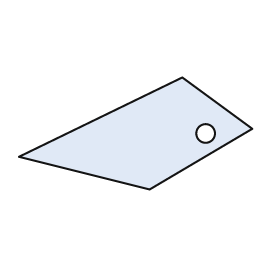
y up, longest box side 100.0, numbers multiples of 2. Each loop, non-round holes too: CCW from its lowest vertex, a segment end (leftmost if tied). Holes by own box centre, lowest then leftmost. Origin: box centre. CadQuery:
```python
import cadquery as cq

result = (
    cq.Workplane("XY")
    .moveTo(6.0, -24.0)
    .lineTo(50.0, 2.0)
    .lineTo(20.0, 24.0)
    .lineTo(-50.0, -10.0)
    .close()
    .moveTo(30.0, 0.0)
    .circle(4.0)
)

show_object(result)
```